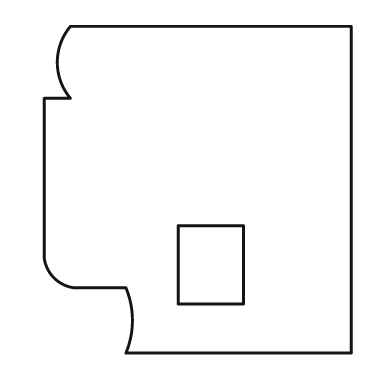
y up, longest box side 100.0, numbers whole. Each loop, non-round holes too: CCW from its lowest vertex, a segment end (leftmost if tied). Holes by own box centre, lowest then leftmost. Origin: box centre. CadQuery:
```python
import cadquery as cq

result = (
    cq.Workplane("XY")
    .moveTo(-22.0, -50.0)
    .lineTo(47.0, -50.0)
    .lineTo(47.0, 50.0)
    .lineTo(-39.0, 50.0)
    .threePointArc((-43.0, 39.0), (-39.0, 28.0))
    .lineTo(-47.0, 28.0)
    .lineTo(-47.0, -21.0)
    .threePointArc((-44.0, -27.0), (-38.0, -30.0))
    .lineTo(-22.0, -30.0)
    .threePointArc((-20.0, -40.0), (-22.0, -50.0))
    .close()
    .moveTo(-6.0, -35.0)
    .lineTo(14.0, -35.0)
    .lineTo(14.0, -11.0)
    .lineTo(-6.0, -11.0)
    .close()
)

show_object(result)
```